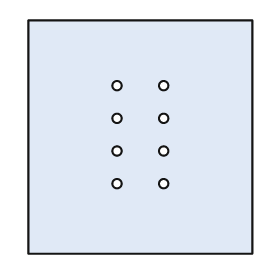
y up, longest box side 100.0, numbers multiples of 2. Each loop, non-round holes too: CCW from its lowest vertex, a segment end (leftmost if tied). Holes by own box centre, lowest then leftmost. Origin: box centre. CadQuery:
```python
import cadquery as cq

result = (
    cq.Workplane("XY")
    .moveTo(-48.0, -50.0)
    .lineTo(48.0, -50.0)
    .lineTo(48.0, 50.0)
    .lineTo(-48.0, 50.0)
    .close()
    .moveTo(-10.0, -20.0)
    .circle(2.0)
    .moveTo(10.0, -20.0)
    .circle(2.0)
    .moveTo(-10.0, -6.0)
    .circle(2.0)
    .moveTo(10.0, -6.0)
    .circle(2.0)
    .moveTo(-10.0, 8.0)
    .circle(2.0)
    .moveTo(10.0, 8.0)
    .circle(2.0)
    .moveTo(-10.0, 22.0)
    .circle(2.0)
    .moveTo(10.0, 22.0)
    .circle(2.0)
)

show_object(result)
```